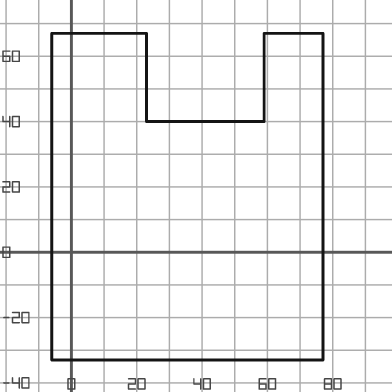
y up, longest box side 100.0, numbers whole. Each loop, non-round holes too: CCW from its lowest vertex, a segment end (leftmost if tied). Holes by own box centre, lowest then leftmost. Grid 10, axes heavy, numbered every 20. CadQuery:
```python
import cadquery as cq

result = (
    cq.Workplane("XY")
    .moveTo(-6.0, -33.0)
    .lineTo(77.0, -33.0)
    .lineTo(77.0, 67.0)
    .lineTo(59.0, 67.0)
    .lineTo(59.0, 40.0)
    .lineTo(23.0, 40.0)
    .lineTo(23.0, 67.0)
    .lineTo(-6.0, 67.0)
    .close()
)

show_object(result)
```